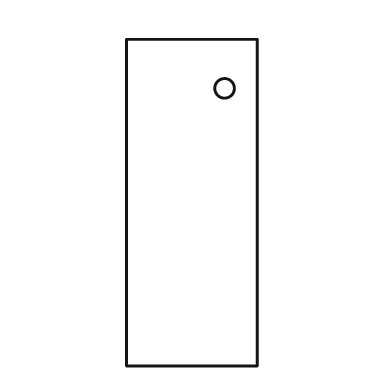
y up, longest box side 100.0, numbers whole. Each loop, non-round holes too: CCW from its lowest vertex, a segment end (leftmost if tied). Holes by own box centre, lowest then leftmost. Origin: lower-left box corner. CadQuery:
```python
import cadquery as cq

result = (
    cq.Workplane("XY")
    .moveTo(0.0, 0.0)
    .lineTo(40.0, 0.0)
    .lineTo(40.0, 100.0)
    .lineTo(0.0, 100.0)
    .close()
    .moveTo(30.0, 85.0)
    .circle(3.0)
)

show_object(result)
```